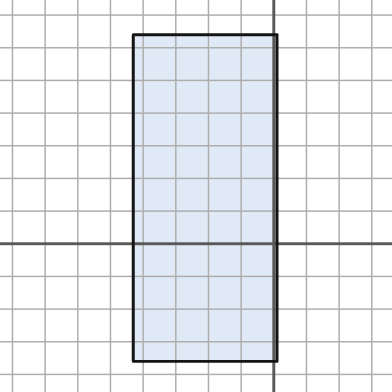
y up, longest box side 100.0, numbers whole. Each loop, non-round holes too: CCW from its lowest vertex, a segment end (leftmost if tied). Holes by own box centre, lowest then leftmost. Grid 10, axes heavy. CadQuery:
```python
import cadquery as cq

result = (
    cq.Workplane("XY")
    .moveTo(-43.0, -36.0)
    .lineTo(1.0, -36.0)
    .lineTo(1.0, 64.0)
    .lineTo(-43.0, 64.0)
    .close()
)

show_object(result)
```